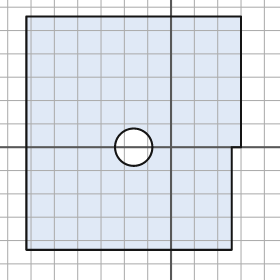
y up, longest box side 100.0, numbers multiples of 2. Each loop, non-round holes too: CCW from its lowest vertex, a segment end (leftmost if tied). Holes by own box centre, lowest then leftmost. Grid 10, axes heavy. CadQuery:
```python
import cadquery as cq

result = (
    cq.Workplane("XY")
    .moveTo(-62.0, -44.0)
    .lineTo(26.0, -44.0)
    .lineTo(26.0, 0.0)
    .lineTo(30.0, 0.0)
    .lineTo(30.0, 56.0)
    .lineTo(-62.0, 56.0)
    .close()
    .moveTo(-16.0, 0.0)
    .circle(8.0)
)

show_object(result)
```